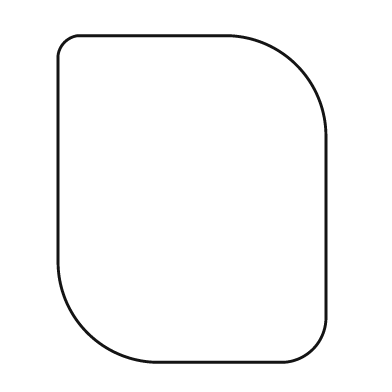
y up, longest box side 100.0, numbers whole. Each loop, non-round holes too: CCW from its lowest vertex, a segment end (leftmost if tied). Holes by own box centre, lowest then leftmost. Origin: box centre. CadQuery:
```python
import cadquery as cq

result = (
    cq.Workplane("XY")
    .moveTo(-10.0, -50.0)
    .lineTo(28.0, -50.0)
    .threePointArc((37.0, -46.0), (41.0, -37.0))
    .lineTo(41.0, 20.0)
    .threePointArc((32.0, 41.0), (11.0, 50.0))
    .lineTo(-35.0, 50.0)
    .threePointArc((-39.0, 48.0), (-41.0, 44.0))
    .lineTo(-41.0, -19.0)
    .threePointArc((-32.0, -41.0), (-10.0, -50.0))
    .close()
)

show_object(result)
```